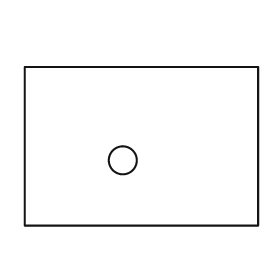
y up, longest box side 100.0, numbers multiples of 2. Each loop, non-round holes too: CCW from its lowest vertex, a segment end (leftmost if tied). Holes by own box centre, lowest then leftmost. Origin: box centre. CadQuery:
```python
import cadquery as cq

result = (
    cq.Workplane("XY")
    .moveTo(-50.0, -34.0)
    .lineTo(50.0, -34.0)
    .lineTo(50.0, 34.0)
    .lineTo(-50.0, 34.0)
    .close()
    .moveTo(-8.0, -6.0)
    .circle(6.0)
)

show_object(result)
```